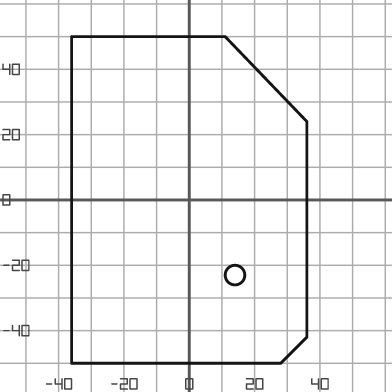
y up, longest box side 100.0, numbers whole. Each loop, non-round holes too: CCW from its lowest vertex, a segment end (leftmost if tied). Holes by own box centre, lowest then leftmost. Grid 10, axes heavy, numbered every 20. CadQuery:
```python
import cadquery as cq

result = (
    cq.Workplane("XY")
    .moveTo(-36.0, -50.0)
    .lineTo(28.0, -50.0)
    .lineTo(36.0, -42.0)
    .lineTo(36.0, 24.0)
    .lineTo(11.0, 50.0)
    .lineTo(-36.0, 50.0)
    .close()
    .moveTo(14.0, -23.0)
    .circle(3.0)
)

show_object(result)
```